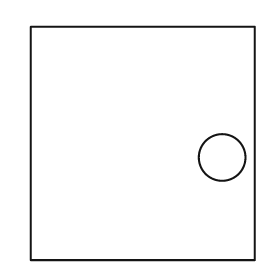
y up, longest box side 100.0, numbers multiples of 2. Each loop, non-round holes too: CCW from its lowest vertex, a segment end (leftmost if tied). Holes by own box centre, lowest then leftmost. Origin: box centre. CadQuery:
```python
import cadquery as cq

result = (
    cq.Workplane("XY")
    .moveTo(-48.0, -50.0)
    .lineTo(48.0, -50.0)
    .lineTo(48.0, 50.0)
    .lineTo(-48.0, 50.0)
    .close()
    .moveTo(34.0, -6.0)
    .circle(10.0)
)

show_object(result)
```